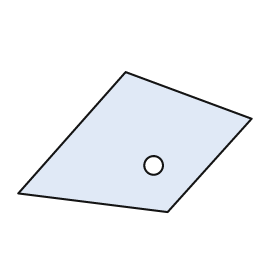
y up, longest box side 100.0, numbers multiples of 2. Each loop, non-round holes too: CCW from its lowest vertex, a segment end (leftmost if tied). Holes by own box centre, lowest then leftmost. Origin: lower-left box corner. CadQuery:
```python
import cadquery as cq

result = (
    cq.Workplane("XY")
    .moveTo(64.0, 0.0)
    .lineTo(100.0, 40.0)
    .lineTo(46.0, 60.0)
    .lineTo(0.0, 8.0)
    .close()
    .moveTo(58.0, 20.0)
    .circle(4.0)
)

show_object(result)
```